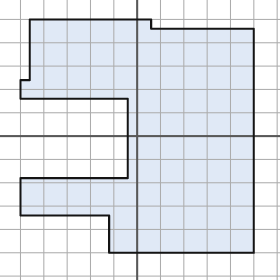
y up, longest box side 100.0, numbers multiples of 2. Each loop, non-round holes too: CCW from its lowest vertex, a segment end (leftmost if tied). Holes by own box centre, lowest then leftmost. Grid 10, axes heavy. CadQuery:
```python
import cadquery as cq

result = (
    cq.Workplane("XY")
    .moveTo(-12.0, -50.0)
    .lineTo(50.0, -50.0)
    .lineTo(50.0, 46.0)
    .lineTo(6.0, 46.0)
    .lineTo(6.0, 50.0)
    .lineTo(-46.0, 50.0)
    .lineTo(-46.0, 24.0)
    .lineTo(-50.0, 24.0)
    .lineTo(-50.0, 16.0)
    .lineTo(-4.0, 16.0)
    .lineTo(-4.0, -18.0)
    .lineTo(-50.0, -18.0)
    .lineTo(-50.0, -34.0)
    .lineTo(-12.0, -34.0)
    .close()
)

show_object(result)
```